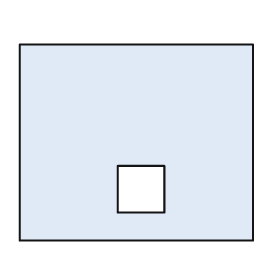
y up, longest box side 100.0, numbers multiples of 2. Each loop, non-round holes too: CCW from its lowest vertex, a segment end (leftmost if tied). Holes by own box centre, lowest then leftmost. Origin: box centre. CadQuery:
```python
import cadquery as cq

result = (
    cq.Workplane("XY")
    .moveTo(-50.0, -42.0)
    .lineTo(50.0, -42.0)
    .lineTo(50.0, 42.0)
    .lineTo(-50.0, 42.0)
    .close()
    .moveTo(-8.0, -30.0)
    .lineTo(12.0, -30.0)
    .lineTo(12.0, -10.0)
    .lineTo(-8.0, -10.0)
    .close()
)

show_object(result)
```